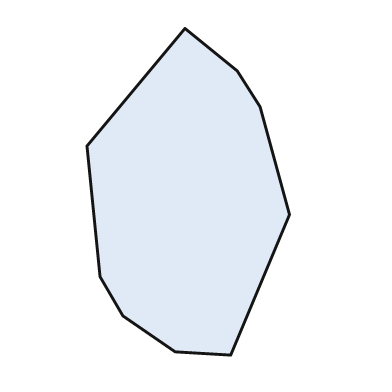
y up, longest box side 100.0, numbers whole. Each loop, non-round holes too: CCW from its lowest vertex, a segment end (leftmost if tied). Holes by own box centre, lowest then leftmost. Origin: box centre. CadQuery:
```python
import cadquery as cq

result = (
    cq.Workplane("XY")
    .moveTo(13.0, -50.0)
    .lineTo(31.0, -7.0)
    .lineTo(22.0, 26.0)
    .lineTo(15.0, 37.0)
    .lineTo(-1.0, 50.0)
    .lineTo(-31.0, 14.0)
    .lineTo(-27.0, -26.0)
    .lineTo(-20.0, -38.0)
    .lineTo(-4.0, -49.0)
    .close()
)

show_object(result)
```